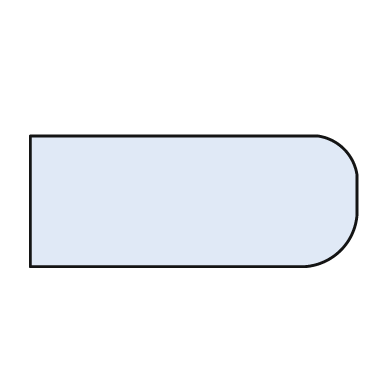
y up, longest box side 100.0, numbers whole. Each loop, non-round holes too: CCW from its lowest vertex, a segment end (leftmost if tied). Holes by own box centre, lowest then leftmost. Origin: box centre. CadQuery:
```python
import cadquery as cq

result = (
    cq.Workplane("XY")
    .moveTo(-50.0, -20.0)
    .lineTo(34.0, -20.0)
    .threePointArc((45.0, -15.0), (50.0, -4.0))
    .lineTo(50.0, 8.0)
    .threePointArc((46.0, 16.0), (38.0, 20.0))
    .lineTo(-50.0, 20.0)
    .close()
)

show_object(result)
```